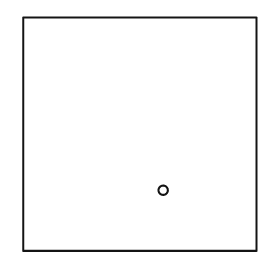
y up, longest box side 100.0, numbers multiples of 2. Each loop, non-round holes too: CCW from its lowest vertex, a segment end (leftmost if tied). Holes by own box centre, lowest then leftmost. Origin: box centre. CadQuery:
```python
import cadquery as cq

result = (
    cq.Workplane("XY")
    .moveTo(-50.0, -50.0)
    .lineTo(50.0, -50.0)
    .lineTo(50.0, 50.0)
    .lineTo(-50.0, 50.0)
    .close()
    .moveTo(10.0, -24.0)
    .circle(2.0)
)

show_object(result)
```